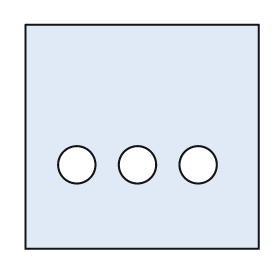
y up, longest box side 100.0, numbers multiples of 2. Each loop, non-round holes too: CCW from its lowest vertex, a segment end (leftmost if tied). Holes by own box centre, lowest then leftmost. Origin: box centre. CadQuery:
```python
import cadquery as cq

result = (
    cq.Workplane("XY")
    .moveTo(-50.0, -48.0)
    .lineTo(50.0, -48.0)
    .lineTo(50.0, 48.0)
    .lineTo(-50.0, 48.0)
    .close()
    .moveTo(-28.0, -12.0)
    .circle(8.0)
    .moveTo(-2.0, -12.0)
    .circle(8.0)
    .moveTo(24.0, -12.0)
    .circle(8.0)
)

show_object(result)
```